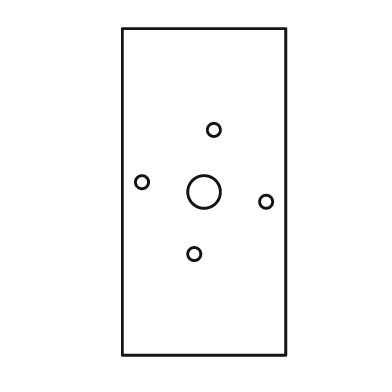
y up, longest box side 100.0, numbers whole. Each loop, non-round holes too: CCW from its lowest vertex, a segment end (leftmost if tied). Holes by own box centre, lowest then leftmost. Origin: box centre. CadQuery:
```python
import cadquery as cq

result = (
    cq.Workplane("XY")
    .moveTo(-25.0, -50.0)
    .lineTo(25.0, -50.0)
    .lineTo(25.0, 50.0)
    .lineTo(-25.0, 50.0)
    .close()
    .moveTo(-3.0, -19.0)
    .circle(2.0)
    .moveTo(19.0, -3.0)
    .circle(2.0)
    .moveTo(0.0, 0.0)
    .circle(5.0)
    .moveTo(-19.0, 3.0)
    .circle(2.0)
    .moveTo(3.0, 19.0)
    .circle(2.0)
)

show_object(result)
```